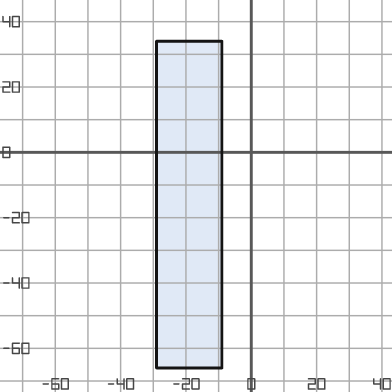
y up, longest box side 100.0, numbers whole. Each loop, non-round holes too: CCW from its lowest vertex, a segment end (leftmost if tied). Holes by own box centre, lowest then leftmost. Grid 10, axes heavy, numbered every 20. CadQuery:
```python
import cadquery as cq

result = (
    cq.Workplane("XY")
    .moveTo(-29.0, -66.0)
    .lineTo(-9.0, -66.0)
    .lineTo(-9.0, 34.0)
    .lineTo(-29.0, 34.0)
    .close()
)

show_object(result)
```